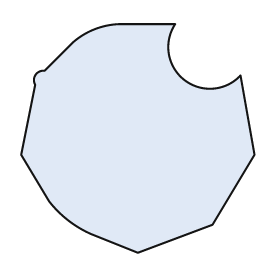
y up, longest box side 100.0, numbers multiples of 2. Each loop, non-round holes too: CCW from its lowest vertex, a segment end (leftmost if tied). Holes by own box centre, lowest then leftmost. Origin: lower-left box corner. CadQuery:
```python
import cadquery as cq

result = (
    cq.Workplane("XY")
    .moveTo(50.0, 0.0)
    .lineTo(82.0, 12.0)
    .lineTo(100.0, 42.0)
    .lineTo(94.0, 76.0)
    .threePointArc((70.0, 74.0), (66.0, 98.0))
    .lineTo(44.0, 98.0)
    .threePointArc((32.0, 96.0), (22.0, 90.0))
    .lineTo(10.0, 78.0)
    .threePointArc((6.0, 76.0), (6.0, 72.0))
    .lineTo(0.0, 42.0)
    .lineTo(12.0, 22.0)
    .threePointArc((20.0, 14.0), (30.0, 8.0))
    .close()
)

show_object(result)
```